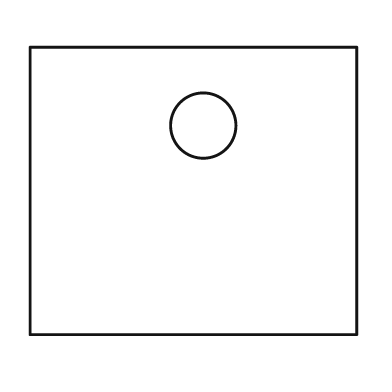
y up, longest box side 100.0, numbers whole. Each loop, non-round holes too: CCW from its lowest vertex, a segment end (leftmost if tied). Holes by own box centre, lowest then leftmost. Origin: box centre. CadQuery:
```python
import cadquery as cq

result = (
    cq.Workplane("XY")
    .moveTo(-50.0, -44.0)
    .lineTo(50.0, -44.0)
    .lineTo(50.0, 44.0)
    .lineTo(-50.0, 44.0)
    .close()
    .moveTo(3.0, 20.0)
    .circle(10.0)
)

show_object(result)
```